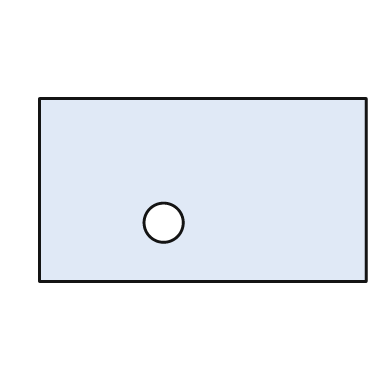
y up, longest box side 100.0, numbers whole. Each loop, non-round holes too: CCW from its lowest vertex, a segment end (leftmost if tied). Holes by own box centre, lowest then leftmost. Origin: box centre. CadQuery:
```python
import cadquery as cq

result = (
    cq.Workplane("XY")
    .moveTo(-50.0, -28.0)
    .lineTo(50.0, -28.0)
    .lineTo(50.0, 28.0)
    .lineTo(-50.0, 28.0)
    .close()
    .moveTo(-12.0, -10.0)
    .circle(6.0)
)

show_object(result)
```